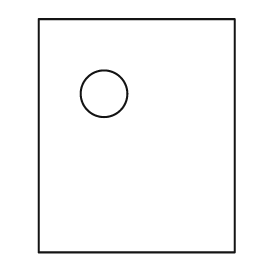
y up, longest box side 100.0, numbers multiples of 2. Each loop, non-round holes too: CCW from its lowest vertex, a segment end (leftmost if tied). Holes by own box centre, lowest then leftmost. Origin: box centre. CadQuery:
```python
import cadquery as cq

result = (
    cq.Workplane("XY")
    .moveTo(-42.0, -50.0)
    .lineTo(42.0, -50.0)
    .lineTo(42.0, 50.0)
    .lineTo(-42.0, 50.0)
    .close()
    .moveTo(-14.0, 18.0)
    .circle(10.0)
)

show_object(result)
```